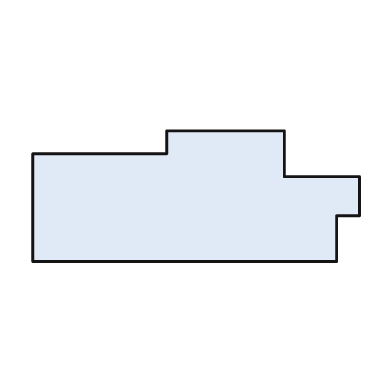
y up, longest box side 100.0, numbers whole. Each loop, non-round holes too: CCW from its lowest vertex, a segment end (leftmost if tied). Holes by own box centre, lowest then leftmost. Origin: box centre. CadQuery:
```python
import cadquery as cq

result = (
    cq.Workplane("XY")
    .moveTo(-50.0, -20.0)
    .lineTo(43.0, -20.0)
    .lineTo(43.0, -6.0)
    .lineTo(50.0, -6.0)
    .lineTo(50.0, 6.0)
    .lineTo(27.0, 6.0)
    .lineTo(27.0, 20.0)
    .lineTo(-9.0, 20.0)
    .lineTo(-9.0, 13.0)
    .lineTo(-50.0, 13.0)
    .close()
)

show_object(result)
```